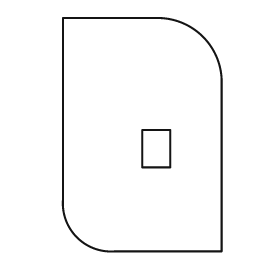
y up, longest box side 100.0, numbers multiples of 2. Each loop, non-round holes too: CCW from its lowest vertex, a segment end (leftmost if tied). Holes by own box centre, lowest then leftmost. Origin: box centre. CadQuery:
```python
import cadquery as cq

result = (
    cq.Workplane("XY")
    .moveTo(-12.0, -50.0)
    .lineTo(34.0, -50.0)
    .lineTo(34.0, 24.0)
    .threePointArc((26.0, 42.0), (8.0, 50.0))
    .lineTo(-34.0, 50.0)
    .lineTo(-34.0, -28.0)
    .threePointArc((-28.0, -44.0), (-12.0, -50.0))
    .close()
    .moveTo(0.0, -14.0)
    .lineTo(12.0, -14.0)
    .lineTo(12.0, 2.0)
    .lineTo(0.0, 2.0)
    .close()
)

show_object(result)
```